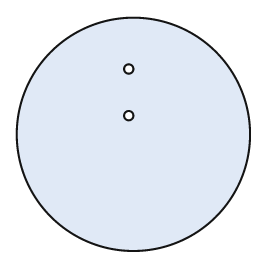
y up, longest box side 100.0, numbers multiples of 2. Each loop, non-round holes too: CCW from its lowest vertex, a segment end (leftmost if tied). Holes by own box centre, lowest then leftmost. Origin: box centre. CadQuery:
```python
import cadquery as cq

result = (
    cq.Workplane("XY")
    .moveTo(0.0, 0.0)
    .circle(50.0)
    .moveTo(-2.0, 8.0)
    .circle(2.0)
    .moveTo(-2.0, 28.0)
    .circle(2.0)
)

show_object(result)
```